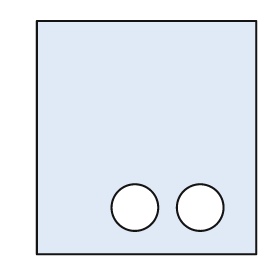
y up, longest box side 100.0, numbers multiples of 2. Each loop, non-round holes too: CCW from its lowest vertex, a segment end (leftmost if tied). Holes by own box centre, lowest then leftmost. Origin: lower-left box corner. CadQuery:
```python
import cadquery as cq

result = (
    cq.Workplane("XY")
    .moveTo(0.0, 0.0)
    .lineTo(94.0, 0.0)
    .lineTo(94.0, 100.0)
    .lineTo(0.0, 100.0)
    .close()
    .moveTo(42.0, 20.0)
    .circle(10.0)
    .moveTo(70.0, 20.0)
    .circle(10.0)
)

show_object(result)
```